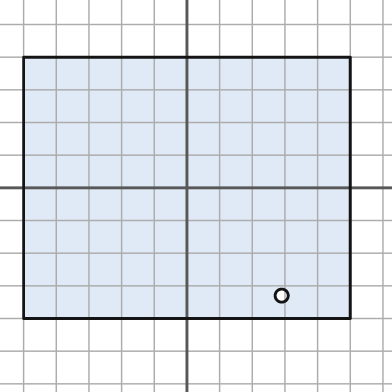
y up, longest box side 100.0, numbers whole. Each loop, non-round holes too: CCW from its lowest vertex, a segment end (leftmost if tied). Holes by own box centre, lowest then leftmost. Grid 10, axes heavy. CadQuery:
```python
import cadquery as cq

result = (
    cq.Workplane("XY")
    .moveTo(-50.0, -40.0)
    .lineTo(50.0, -40.0)
    .lineTo(50.0, 40.0)
    .lineTo(-50.0, 40.0)
    .close()
    .moveTo(29.0, -33.0)
    .circle(2.0)
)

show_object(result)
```